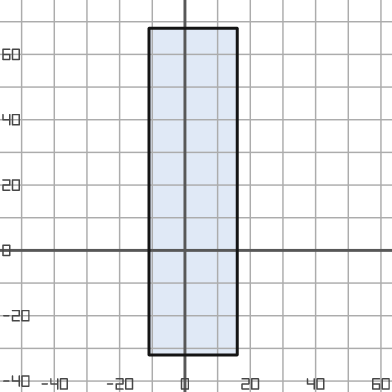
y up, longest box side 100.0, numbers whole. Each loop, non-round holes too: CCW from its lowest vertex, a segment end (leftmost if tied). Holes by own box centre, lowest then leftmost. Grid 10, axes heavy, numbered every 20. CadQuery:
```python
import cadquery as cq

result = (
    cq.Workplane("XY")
    .moveTo(-11.0, -32.0)
    .lineTo(16.0, -32.0)
    .lineTo(16.0, 68.0)
    .lineTo(-11.0, 68.0)
    .close()
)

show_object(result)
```